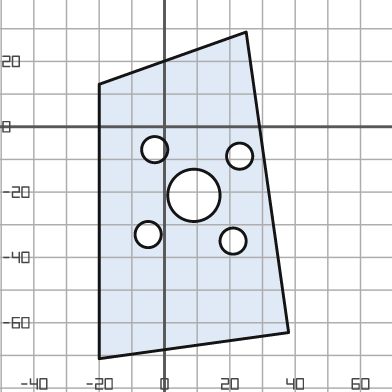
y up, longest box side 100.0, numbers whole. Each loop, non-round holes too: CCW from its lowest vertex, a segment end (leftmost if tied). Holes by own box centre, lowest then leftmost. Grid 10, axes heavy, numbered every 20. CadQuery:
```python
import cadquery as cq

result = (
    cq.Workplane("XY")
    .moveTo(-20.0, -71.0)
    .lineTo(38.0, -63.0)
    .lineTo(25.0, 29.0)
    .lineTo(-20.0, 13.0)
    .close()
    .moveTo(21.0, -35.0)
    .circle(4.0)
    .moveTo(-5.0, -33.0)
    .circle(4.0)
    .moveTo(9.0, -21.0)
    .circle(8.0)
    .moveTo(23.0, -9.0)
    .circle(4.0)
    .moveTo(-3.0, -7.0)
    .circle(4.0)
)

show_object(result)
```